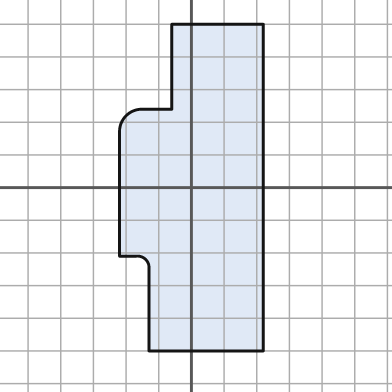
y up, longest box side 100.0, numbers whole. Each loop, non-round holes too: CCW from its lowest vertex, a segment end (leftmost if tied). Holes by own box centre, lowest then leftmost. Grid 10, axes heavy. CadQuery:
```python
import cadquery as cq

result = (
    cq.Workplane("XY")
    .moveTo(-13.0, -50.0)
    .lineTo(22.0, -50.0)
    .lineTo(22.0, 50.0)
    .lineTo(-6.0, 50.0)
    .lineTo(-6.0, 24.0)
    .lineTo(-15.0, 24.0)
    .threePointArc((-20.0, 22.0), (-22.0, 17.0))
    .lineTo(-22.0, -21.0)
    .lineTo(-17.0, -21.0)
    .threePointArc((-14.0, -22.0), (-13.0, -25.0))
    .close()
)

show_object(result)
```